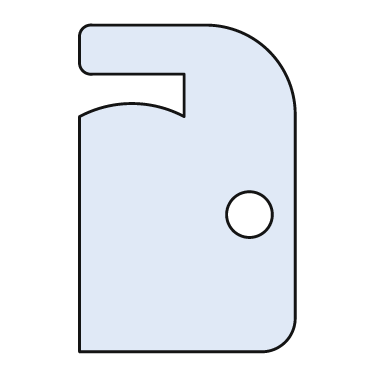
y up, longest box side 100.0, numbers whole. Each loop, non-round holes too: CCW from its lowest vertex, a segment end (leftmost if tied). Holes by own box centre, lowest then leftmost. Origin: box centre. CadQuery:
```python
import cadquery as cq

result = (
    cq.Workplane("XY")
    .moveTo(-33.0, -50.0)
    .lineTo(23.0, -50.0)
    .threePointArc((30.0, -47.0), (33.0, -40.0))
    .lineTo(33.0, 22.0)
    .threePointArc((25.0, 42.0), (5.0, 50.0))
    .lineTo(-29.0, 50.0)
    .threePointArc((-32.0, 49.0), (-33.0, 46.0))
    .lineTo(-33.0, 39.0)
    .threePointArc((-32.0, 36.0), (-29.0, 35.0))
    .lineTo(-1.0, 35.0)
    .lineTo(-1.0, 22.0)
    .threePointArc((-17.0, 26.0), (-33.0, 22.0))
    .close()
    .moveTo(19.0, -8.0)
    .circle(7.0)
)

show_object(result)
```